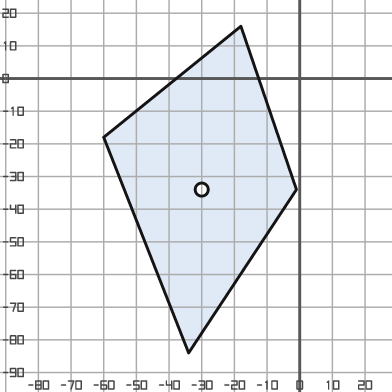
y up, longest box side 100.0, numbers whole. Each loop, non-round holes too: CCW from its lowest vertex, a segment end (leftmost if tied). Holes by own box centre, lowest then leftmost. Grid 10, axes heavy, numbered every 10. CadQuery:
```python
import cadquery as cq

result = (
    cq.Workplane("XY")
    .moveTo(-34.0, -84.0)
    .lineTo(-1.0, -34.0)
    .lineTo(-18.0, 16.0)
    .lineTo(-60.0, -18.0)
    .close()
    .moveTo(-30.0, -34.0)
    .circle(2.0)
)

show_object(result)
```